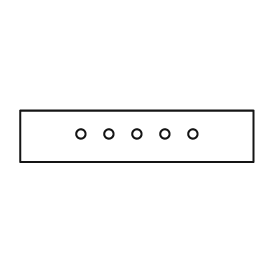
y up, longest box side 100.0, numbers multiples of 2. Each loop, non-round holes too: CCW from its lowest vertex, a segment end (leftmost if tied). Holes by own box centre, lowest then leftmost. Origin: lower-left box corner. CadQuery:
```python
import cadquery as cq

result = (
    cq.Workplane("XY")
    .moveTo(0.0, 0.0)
    .lineTo(100.0, 0.0)
    .lineTo(100.0, 22.0)
    .lineTo(0.0, 22.0)
    .close()
    .moveTo(26.0, 12.0)
    .circle(2.0)
    .moveTo(38.0, 12.0)
    .circle(2.0)
    .moveTo(50.0, 12.0)
    .circle(2.0)
    .moveTo(62.0, 12.0)
    .circle(2.0)
    .moveTo(74.0, 12.0)
    .circle(2.0)
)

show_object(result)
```